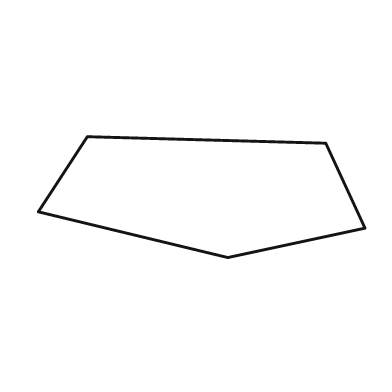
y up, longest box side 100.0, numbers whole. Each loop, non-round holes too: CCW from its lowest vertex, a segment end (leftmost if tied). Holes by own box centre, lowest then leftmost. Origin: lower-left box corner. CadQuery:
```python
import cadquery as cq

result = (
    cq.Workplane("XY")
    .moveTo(58.0, 0.0)
    .lineTo(100.0, 9.0)
    .lineTo(88.0, 35.0)
    .lineTo(15.0, 37.0)
    .lineTo(0.0, 14.0)
    .close()
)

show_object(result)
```